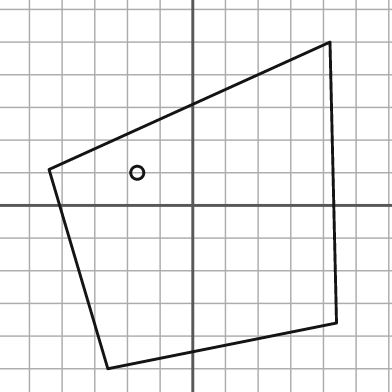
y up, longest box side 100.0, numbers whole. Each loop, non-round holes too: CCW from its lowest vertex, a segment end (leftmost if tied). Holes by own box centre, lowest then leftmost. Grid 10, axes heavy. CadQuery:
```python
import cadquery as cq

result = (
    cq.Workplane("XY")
    .moveTo(-26.0, -50.0)
    .lineTo(44.0, -36.0)
    .lineTo(42.0, 50.0)
    .lineTo(-44.0, 11.0)
    .close()
    .moveTo(-17.0, 10.0)
    .circle(2.0)
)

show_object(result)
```